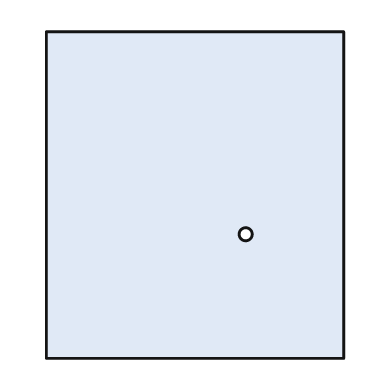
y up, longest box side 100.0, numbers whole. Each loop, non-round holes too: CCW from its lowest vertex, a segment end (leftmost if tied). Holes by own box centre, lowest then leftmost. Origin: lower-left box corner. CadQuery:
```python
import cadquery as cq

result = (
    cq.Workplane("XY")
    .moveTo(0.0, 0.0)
    .lineTo(91.0, 0.0)
    .lineTo(91.0, 100.0)
    .lineTo(0.0, 100.0)
    .close()
    .moveTo(61.0, 38.0)
    .circle(2.0)
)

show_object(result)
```